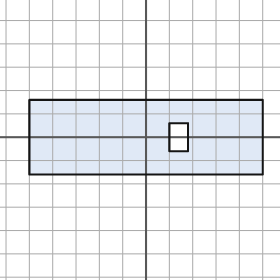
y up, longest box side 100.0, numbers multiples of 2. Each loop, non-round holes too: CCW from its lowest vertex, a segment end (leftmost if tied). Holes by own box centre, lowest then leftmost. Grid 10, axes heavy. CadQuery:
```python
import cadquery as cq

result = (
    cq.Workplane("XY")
    .moveTo(-50.0, -16.0)
    .lineTo(50.0, -16.0)
    .lineTo(50.0, 16.0)
    .lineTo(-50.0, 16.0)
    .close()
    .moveTo(10.0, -6.0)
    .lineTo(18.0, -6.0)
    .lineTo(18.0, 6.0)
    .lineTo(10.0, 6.0)
    .close()
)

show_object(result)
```